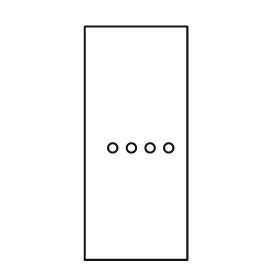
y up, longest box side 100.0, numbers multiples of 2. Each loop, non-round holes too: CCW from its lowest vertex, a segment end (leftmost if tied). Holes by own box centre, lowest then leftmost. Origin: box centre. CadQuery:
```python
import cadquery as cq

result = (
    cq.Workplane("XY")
    .moveTo(-22.0, -50.0)
    .lineTo(22.0, -50.0)
    .lineTo(22.0, 50.0)
    .lineTo(-22.0, 50.0)
    .close()
    .moveTo(-10.0, -2.0)
    .circle(2.0)
    .moveTo(-2.0, -2.0)
    .circle(2.0)
    .moveTo(6.0, -2.0)
    .circle(2.0)
    .moveTo(14.0, -2.0)
    .circle(2.0)
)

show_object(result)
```